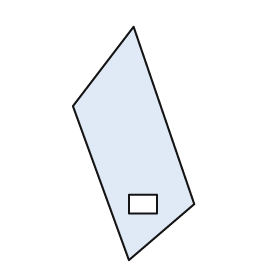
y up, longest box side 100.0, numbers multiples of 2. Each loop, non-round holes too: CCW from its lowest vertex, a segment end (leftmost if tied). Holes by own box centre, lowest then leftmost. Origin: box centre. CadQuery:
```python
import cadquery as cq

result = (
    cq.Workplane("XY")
    .moveTo(-2.0, -50.0)
    .lineTo(26.0, -26.0)
    .lineTo(0.0, 50.0)
    .lineTo(-26.0, 16.0)
    .close()
    .moveTo(-2.0, -30.0)
    .lineTo(10.0, -30.0)
    .lineTo(10.0, -22.0)
    .lineTo(-2.0, -22.0)
    .close()
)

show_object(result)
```